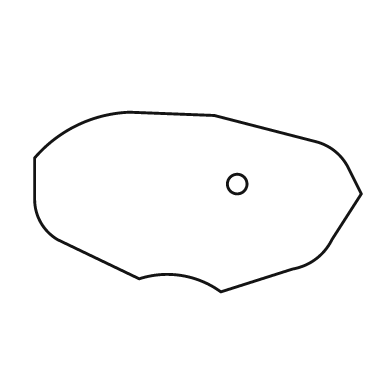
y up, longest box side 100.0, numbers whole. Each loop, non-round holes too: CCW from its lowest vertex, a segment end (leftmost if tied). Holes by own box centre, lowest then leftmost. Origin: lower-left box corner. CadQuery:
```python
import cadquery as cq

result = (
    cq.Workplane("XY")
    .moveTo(57.0, 0.0)
    .lineTo(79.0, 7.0)
    .threePointArc((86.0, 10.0), (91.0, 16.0))
    .lineTo(100.0, 30.0)
    .lineTo(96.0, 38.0)
    .threePointArc((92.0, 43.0), (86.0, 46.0))
    .lineTo(55.0, 54.0)
    .lineTo(29.0, 55.0)
    .threePointArc((13.0, 51.0), (0.0, 41.0))
    .lineTo(0.0, 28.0)
    .threePointArc((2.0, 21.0), (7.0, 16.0))
    .lineTo(32.0, 4.0)
    .threePointArc((45.0, 5.0), (57.0, 0.0))
    .close()
    .moveTo(62.0, 33.0)
    .circle(3.0)
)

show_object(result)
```